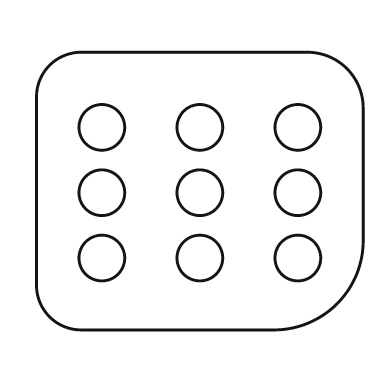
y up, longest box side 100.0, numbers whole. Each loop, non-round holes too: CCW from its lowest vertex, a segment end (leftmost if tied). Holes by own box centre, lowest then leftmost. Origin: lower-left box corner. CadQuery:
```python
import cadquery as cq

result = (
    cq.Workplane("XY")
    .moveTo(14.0, 0.0)
    .lineTo(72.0, 0.0)
    .threePointArc((92.0, 8.0), (100.0, 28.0))
    .lineTo(100.0, 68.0)
    .threePointArc((95.0, 80.0), (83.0, 85.0))
    .lineTo(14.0, 85.0)
    .threePointArc((4.0, 81.0), (0.0, 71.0))
    .lineTo(0.0, 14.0)
    .threePointArc((4.0, 4.0), (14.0, 0.0))
    .close()
    .moveTo(20.0, 22.0)
    .circle(7.0)
    .moveTo(50.0, 22.0)
    .circle(7.0)
    .moveTo(80.0, 22.0)
    .circle(7.0)
    .moveTo(20.0, 42.0)
    .circle(7.0)
    .moveTo(50.0, 42.0)
    .circle(7.0)
    .moveTo(80.0, 42.0)
    .circle(7.0)
    .moveTo(20.0, 62.0)
    .circle(7.0)
    .moveTo(50.0, 62.0)
    .circle(7.0)
    .moveTo(80.0, 62.0)
    .circle(7.0)
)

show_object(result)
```